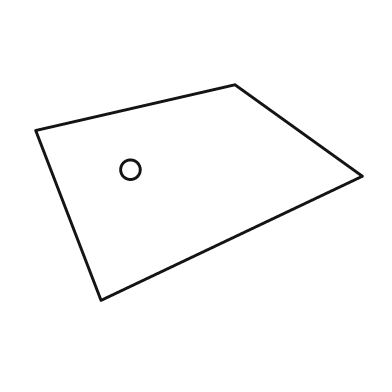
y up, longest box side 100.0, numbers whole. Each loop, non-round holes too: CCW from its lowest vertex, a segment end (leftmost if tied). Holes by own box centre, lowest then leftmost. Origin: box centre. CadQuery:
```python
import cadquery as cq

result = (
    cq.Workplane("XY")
    .moveTo(-30.0, -33.0)
    .lineTo(50.0, 5.0)
    .lineTo(11.0, 33.0)
    .lineTo(-50.0, 19.0)
    .close()
    .moveTo(-21.0, 7.0)
    .circle(3.0)
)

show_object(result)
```